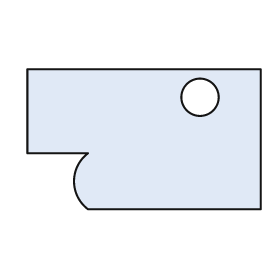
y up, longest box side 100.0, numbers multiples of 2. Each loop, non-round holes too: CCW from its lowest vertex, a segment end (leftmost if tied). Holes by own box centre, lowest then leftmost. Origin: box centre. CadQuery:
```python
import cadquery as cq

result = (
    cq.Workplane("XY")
    .moveTo(-24.0, -30.0)
    .lineTo(50.0, -30.0)
    .lineTo(50.0, 30.0)
    .lineTo(-50.0, 30.0)
    .lineTo(-50.0, -6.0)
    .lineTo(-24.0, -6.0)
    .threePointArc((-30.0, -18.0), (-24.0, -30.0))
    .close()
    .moveTo(24.0, 18.0)
    .circle(8.0)
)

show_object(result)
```